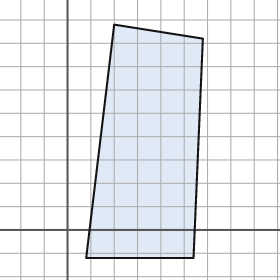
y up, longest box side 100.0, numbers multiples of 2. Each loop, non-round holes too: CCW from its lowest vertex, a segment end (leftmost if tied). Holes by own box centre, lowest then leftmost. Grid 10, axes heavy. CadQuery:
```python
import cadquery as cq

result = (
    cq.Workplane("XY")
    .moveTo(8.0, -12.0)
    .lineTo(54.0, -12.0)
    .lineTo(58.0, 82.0)
    .lineTo(20.0, 88.0)
    .close()
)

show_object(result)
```